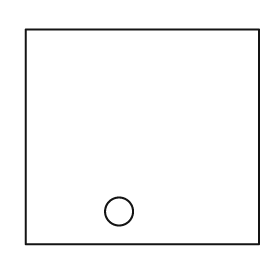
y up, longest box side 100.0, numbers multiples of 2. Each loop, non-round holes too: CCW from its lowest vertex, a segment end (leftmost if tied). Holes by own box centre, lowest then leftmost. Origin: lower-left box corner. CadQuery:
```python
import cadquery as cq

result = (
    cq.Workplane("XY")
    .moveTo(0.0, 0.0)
    .lineTo(100.0, 0.0)
    .lineTo(100.0, 92.0)
    .lineTo(0.0, 92.0)
    .close()
    .moveTo(40.0, 14.0)
    .circle(6.0)
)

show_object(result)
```